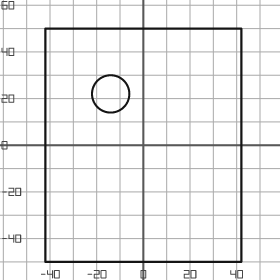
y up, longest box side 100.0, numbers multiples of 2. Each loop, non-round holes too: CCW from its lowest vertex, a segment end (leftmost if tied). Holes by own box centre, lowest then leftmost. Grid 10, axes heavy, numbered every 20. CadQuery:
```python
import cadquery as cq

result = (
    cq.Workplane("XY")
    .moveTo(-42.0, -50.0)
    .lineTo(42.0, -50.0)
    .lineTo(42.0, 50.0)
    .lineTo(-42.0, 50.0)
    .close()
    .moveTo(-14.0, 22.0)
    .circle(8.0)
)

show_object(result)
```